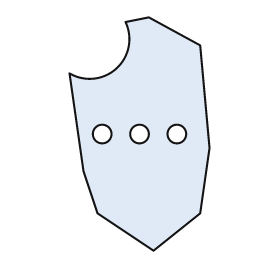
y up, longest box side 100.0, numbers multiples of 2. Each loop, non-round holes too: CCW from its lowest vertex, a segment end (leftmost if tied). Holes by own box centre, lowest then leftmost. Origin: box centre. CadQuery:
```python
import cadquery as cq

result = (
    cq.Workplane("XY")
    .moveTo(6.0, -50.0)
    .lineTo(26.0, -34.0)
    .lineTo(30.0, -6.0)
    .lineTo(26.0, 38.0)
    .lineTo(4.0, 50.0)
    .lineTo(-6.0, 48.0)
    .threePointArc((-10.0, 28.0), (-30.0, 26.0))
    .lineTo(-24.0, -16.0)
    .lineTo(-18.0, -34.0)
    .close()
    .moveTo(-16.0, 0.0)
    .circle(4.0)
    .moveTo(0.0, 0.0)
    .circle(4.0)
    .moveTo(16.0, 0.0)
    .circle(4.0)
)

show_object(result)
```